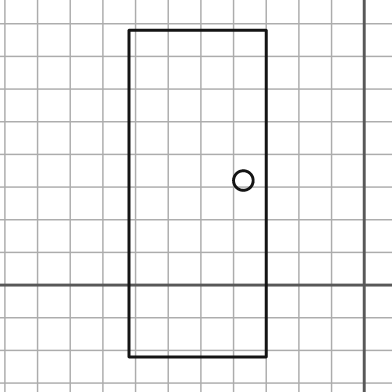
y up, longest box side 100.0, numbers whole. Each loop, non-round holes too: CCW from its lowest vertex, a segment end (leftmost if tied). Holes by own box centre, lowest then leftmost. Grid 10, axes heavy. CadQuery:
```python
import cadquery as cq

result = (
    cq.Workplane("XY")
    .moveTo(-72.0, -22.0)
    .lineTo(-30.0, -22.0)
    .lineTo(-30.0, 78.0)
    .lineTo(-72.0, 78.0)
    .close()
    .moveTo(-37.0, 32.0)
    .circle(3.0)
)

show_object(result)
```